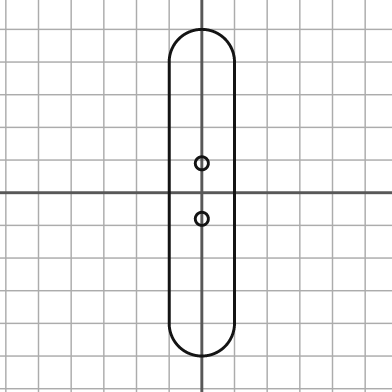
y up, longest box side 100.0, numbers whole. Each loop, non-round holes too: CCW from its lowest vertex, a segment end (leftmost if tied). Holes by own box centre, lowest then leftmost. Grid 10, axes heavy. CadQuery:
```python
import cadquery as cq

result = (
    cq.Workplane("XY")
    .moveTo(-10.0, -40.0)
    .threePointArc((0.0, -50.0), (10.0, -40.0))
    .lineTo(10.0, 40.0)
    .threePointArc((0.0, 50.0), (-10.0, 40.0))
    .close()
    .moveTo(0.0, -8.0)
    .circle(2.0)
    .moveTo(0.0, 9.0)
    .circle(2.0)
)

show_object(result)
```